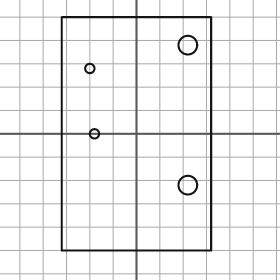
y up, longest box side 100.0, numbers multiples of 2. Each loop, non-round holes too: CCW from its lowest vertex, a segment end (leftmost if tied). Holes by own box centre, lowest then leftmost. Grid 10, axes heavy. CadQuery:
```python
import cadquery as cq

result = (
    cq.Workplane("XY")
    .moveTo(-32.0, -50.0)
    .lineTo(32.0, -50.0)
    .lineTo(32.0, 50.0)
    .lineTo(-32.0, 50.0)
    .close()
    .moveTo(22.0, -22.0)
    .circle(4.0)
    .moveTo(-18.0, 0.0)
    .circle(2.0)
    .moveTo(-20.0, 28.0)
    .circle(2.0)
    .moveTo(22.0, 38.0)
    .circle(4.0)
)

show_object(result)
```